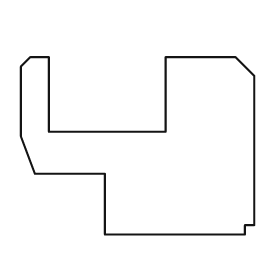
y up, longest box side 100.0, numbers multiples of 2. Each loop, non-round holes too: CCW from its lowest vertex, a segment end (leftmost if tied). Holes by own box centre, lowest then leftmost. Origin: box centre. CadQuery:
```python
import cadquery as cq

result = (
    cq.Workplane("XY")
    .moveTo(-14.0, -38.0)
    .lineTo(46.0, -38.0)
    .lineTo(46.0, -34.0)
    .lineTo(50.0, -34.0)
    .lineTo(50.0, 30.0)
    .lineTo(42.0, 38.0)
    .lineTo(12.0, 38.0)
    .lineTo(12.0, 6.0)
    .lineTo(-38.0, 6.0)
    .lineTo(-38.0, 38.0)
    .lineTo(-46.0, 38.0)
    .lineTo(-50.0, 34.0)
    .lineTo(-50.0, 4.0)
    .lineTo(-44.0, -12.0)
    .lineTo(-14.0, -12.0)
    .close()
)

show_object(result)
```